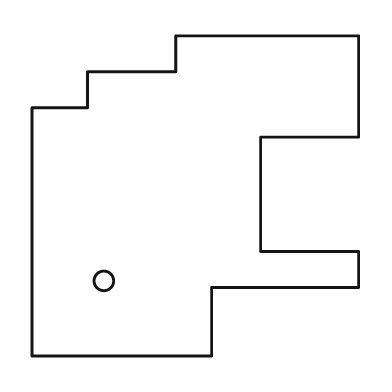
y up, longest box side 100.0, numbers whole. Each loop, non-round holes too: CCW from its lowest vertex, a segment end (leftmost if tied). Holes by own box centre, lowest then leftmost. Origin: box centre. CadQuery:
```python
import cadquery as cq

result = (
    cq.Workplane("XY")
    .moveTo(-50.0, -49.0)
    .lineTo(5.0, -49.0)
    .lineTo(5.0, -28.0)
    .lineTo(50.0, -28.0)
    .lineTo(50.0, -17.0)
    .lineTo(20.0, -17.0)
    .lineTo(20.0, 18.0)
    .lineTo(50.0, 18.0)
    .lineTo(50.0, 49.0)
    .lineTo(-6.0, 49.0)
    .lineTo(-6.0, 38.0)
    .lineTo(-33.0, 38.0)
    .lineTo(-33.0, 27.0)
    .lineTo(-50.0, 27.0)
    .close()
    .moveTo(-28.0, -26.0)
    .circle(3.0)
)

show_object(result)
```